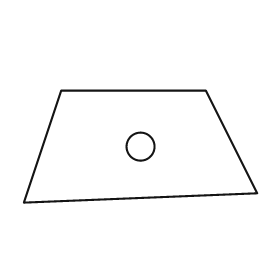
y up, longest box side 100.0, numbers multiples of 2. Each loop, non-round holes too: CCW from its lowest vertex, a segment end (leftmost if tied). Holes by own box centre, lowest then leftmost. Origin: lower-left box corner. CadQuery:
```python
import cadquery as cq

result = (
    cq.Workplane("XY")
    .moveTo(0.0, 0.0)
    .lineTo(100.0, 4.0)
    .lineTo(78.0, 48.0)
    .lineTo(16.0, 48.0)
    .close()
    .moveTo(50.0, 24.0)
    .circle(6.0)
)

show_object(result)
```